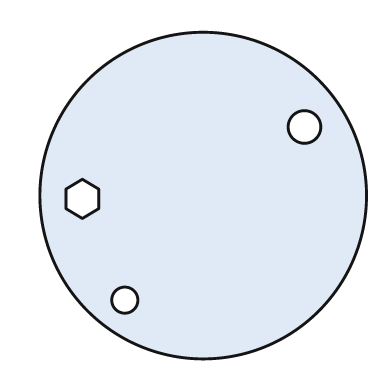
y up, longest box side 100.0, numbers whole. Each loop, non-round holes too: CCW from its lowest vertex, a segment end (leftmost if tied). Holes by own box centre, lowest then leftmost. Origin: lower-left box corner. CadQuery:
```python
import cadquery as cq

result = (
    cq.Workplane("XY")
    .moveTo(50.0, 50.0)
    .circle(50.0)
    .moveTo(26.0, 18.0)
    .circle(4.0)
    .moveTo(13.0, 43.0)
    .lineTo(18.0, 46.0)
    .lineTo(18.0, 52.0)
    .lineTo(13.0, 55.0)
    .lineTo(8.0, 52.0)
    .lineTo(8.0, 46.0)
    .close()
    .moveTo(81.0, 71.0)
    .circle(5.0)
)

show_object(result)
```